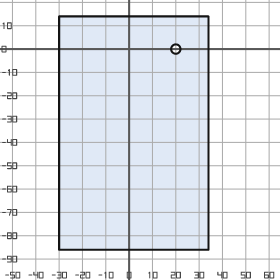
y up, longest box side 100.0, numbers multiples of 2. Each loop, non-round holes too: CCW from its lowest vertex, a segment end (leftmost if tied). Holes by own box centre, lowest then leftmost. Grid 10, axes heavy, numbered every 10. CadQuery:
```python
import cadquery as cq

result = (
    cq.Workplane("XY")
    .moveTo(-30.0, -86.0)
    .lineTo(34.0, -86.0)
    .lineTo(34.0, 14.0)
    .lineTo(-30.0, 14.0)
    .close()
    .moveTo(20.0, 0.0)
    .circle(2.0)
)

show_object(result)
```